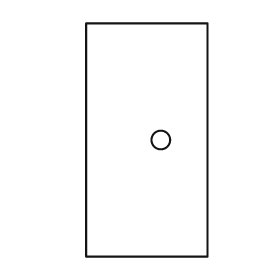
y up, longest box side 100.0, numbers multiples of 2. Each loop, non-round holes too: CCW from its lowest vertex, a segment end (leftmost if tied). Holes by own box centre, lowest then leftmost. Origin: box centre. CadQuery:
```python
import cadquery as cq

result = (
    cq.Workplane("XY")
    .moveTo(-26.0, -50.0)
    .lineTo(26.0, -50.0)
    .lineTo(26.0, 50.0)
    .lineTo(-26.0, 50.0)
    .close()
    .moveTo(6.0, 0.0)
    .circle(4.0)
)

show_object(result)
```